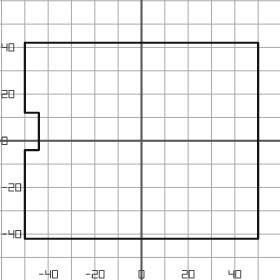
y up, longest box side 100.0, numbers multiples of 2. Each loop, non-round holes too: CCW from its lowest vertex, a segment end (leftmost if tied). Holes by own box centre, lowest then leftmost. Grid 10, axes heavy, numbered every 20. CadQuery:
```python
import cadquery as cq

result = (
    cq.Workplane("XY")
    .moveTo(-50.0, -42.0)
    .lineTo(50.0, -42.0)
    .lineTo(50.0, 42.0)
    .lineTo(-50.0, 42.0)
    .lineTo(-50.0, 12.0)
    .lineTo(-44.0, 12.0)
    .lineTo(-44.0, -4.0)
    .lineTo(-50.0, -4.0)
    .close()
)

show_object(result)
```